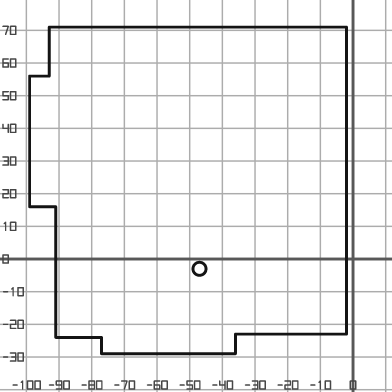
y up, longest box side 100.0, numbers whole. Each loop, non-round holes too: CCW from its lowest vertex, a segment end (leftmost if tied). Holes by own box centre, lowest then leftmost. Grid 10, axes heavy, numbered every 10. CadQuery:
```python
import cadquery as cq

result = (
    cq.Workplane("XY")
    .moveTo(-77.0, -29.0)
    .lineTo(-36.0, -29.0)
    .lineTo(-36.0, -23.0)
    .lineTo(-2.0, -23.0)
    .lineTo(-2.0, 71.0)
    .lineTo(-93.0, 71.0)
    .lineTo(-93.0, 56.0)
    .lineTo(-99.0, 56.0)
    .lineTo(-99.0, 16.0)
    .lineTo(-91.0, 16.0)
    .lineTo(-91.0, -24.0)
    .lineTo(-77.0, -24.0)
    .close()
    .moveTo(-47.0, -3.0)
    .circle(2.0)
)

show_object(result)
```